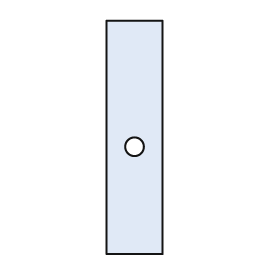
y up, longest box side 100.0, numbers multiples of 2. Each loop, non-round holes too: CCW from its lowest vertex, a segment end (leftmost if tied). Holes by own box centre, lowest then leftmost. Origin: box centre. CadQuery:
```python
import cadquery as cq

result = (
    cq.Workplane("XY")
    .moveTo(-12.0, -50.0)
    .lineTo(12.0, -50.0)
    .lineTo(12.0, 50.0)
    .lineTo(-12.0, 50.0)
    .close()
    .moveTo(0.0, -4.0)
    .circle(4.0)
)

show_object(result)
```